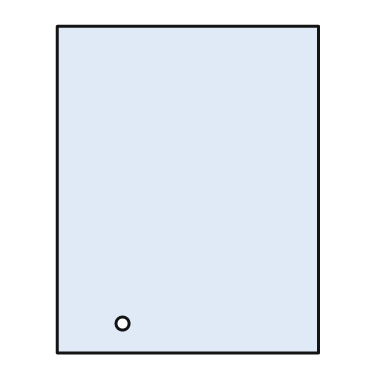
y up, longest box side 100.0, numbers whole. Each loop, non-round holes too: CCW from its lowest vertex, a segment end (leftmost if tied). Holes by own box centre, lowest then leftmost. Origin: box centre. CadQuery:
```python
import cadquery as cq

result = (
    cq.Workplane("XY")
    .moveTo(-40.0, -50.0)
    .lineTo(40.0, -50.0)
    .lineTo(40.0, 50.0)
    .lineTo(-40.0, 50.0)
    .close()
    .moveTo(-20.0, -41.0)
    .circle(2.0)
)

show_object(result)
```